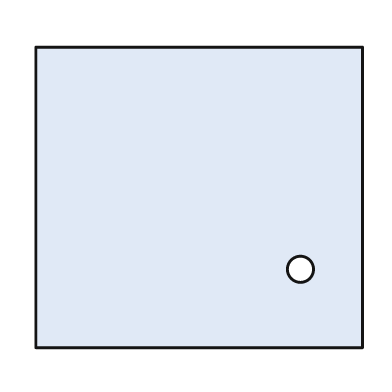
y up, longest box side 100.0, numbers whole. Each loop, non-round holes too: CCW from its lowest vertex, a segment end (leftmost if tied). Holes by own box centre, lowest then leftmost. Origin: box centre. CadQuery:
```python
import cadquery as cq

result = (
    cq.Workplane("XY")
    .moveTo(-50.0, -46.0)
    .lineTo(50.0, -46.0)
    .lineTo(50.0, 46.0)
    .lineTo(-50.0, 46.0)
    .close()
    .moveTo(31.0, -22.0)
    .circle(4.0)
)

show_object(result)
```